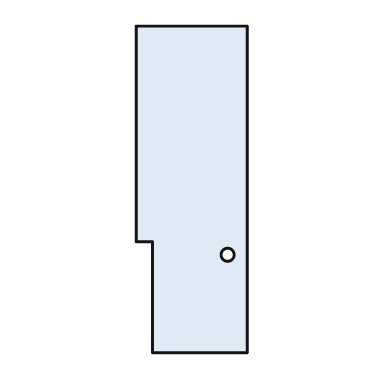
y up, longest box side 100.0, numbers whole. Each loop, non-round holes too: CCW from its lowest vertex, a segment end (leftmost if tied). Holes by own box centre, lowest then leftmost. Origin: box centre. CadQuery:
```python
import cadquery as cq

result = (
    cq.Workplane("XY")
    .moveTo(-12.0, -50.0)
    .lineTo(17.0, -50.0)
    .lineTo(17.0, 50.0)
    .lineTo(-17.0, 50.0)
    .lineTo(-17.0, -16.0)
    .lineTo(-12.0, -16.0)
    .close()
    .moveTo(11.0, -20.0)
    .circle(2.0)
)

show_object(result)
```